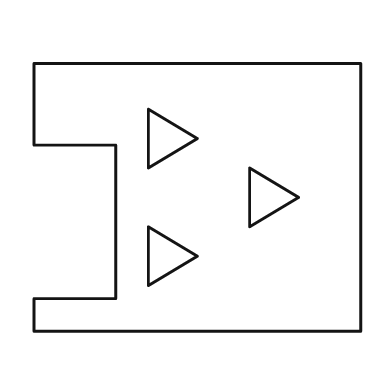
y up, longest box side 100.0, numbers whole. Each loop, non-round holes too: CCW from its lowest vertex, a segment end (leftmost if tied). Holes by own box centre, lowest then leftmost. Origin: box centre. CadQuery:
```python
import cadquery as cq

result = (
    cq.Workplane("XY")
    .moveTo(-50.0, -41.0)
    .lineTo(50.0, -41.0)
    .lineTo(50.0, 41.0)
    .lineTo(-50.0, 41.0)
    .lineTo(-50.0, 16.0)
    .lineTo(-25.0, 16.0)
    .lineTo(-25.0, -31.0)
    .lineTo(-50.0, -31.0)
    .close()
    .moveTo(-15.0, -27.0)
    .lineTo(0.0, -18.0)
    .lineTo(-15.0, -9.0)
    .close()
    .moveTo(16.0, -9.0)
    .lineTo(31.0, 0.0)
    .lineTo(16.0, 9.0)
    .close()
    .moveTo(-15.0, 9.0)
    .lineTo(0.0, 18.0)
    .lineTo(-15.0, 27.0)
    .close()
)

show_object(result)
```